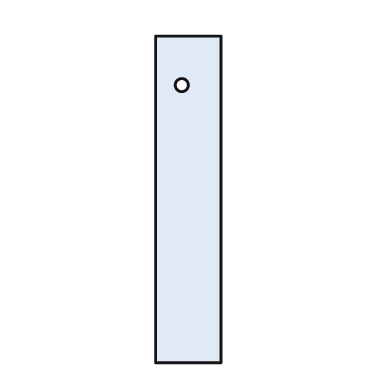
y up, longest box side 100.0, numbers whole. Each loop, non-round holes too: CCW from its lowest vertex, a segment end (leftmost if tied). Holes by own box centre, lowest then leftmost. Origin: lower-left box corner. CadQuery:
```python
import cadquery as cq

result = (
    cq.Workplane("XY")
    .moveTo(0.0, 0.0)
    .lineTo(20.0, 0.0)
    .lineTo(20.0, 100.0)
    .lineTo(0.0, 100.0)
    .close()
    .moveTo(8.0, 85.0)
    .circle(2.0)
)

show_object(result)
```